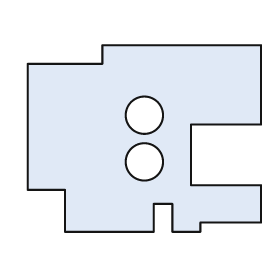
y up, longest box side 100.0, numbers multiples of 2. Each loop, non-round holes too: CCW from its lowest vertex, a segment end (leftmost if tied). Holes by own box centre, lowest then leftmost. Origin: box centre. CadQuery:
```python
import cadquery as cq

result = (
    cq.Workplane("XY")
    .moveTo(-34.0, -40.0)
    .lineTo(4.0, -40.0)
    .lineTo(4.0, -28.0)
    .lineTo(12.0, -28.0)
    .lineTo(12.0, -40.0)
    .lineTo(24.0, -40.0)
    .lineTo(24.0, -36.0)
    .lineTo(50.0, -36.0)
    .lineTo(50.0, -20.0)
    .lineTo(20.0, -20.0)
    .lineTo(20.0, 6.0)
    .lineTo(50.0, 6.0)
    .lineTo(50.0, 40.0)
    .lineTo(-18.0, 40.0)
    .lineTo(-18.0, 32.0)
    .lineTo(-50.0, 32.0)
    .lineTo(-50.0, -22.0)
    .lineTo(-34.0, -22.0)
    .close()
    .moveTo(0.0, -10.0)
    .circle(8.0)
    .moveTo(0.0, 10.0)
    .circle(8.0)
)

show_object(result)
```